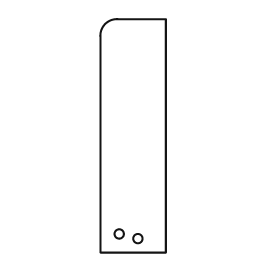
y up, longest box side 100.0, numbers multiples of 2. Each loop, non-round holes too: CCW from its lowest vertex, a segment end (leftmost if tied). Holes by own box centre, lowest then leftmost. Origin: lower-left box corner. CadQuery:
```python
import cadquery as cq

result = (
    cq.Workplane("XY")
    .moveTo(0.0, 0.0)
    .lineTo(28.0, 0.0)
    .lineTo(28.0, 100.0)
    .lineTo(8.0, 100.0)
    .threePointArc((2.0, 98.0), (0.0, 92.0))
    .close()
    .moveTo(16.0, 6.0)
    .circle(2.0)
    .moveTo(8.0, 8.0)
    .circle(2.0)
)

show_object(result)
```